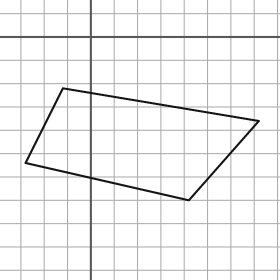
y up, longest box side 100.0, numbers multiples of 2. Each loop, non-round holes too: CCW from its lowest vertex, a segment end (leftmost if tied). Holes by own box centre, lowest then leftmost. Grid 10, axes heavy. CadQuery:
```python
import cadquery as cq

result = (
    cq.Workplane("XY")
    .moveTo(42.0, -70.0)
    .lineTo(72.0, -36.0)
    .lineTo(-12.0, -22.0)
    .lineTo(-28.0, -54.0)
    .close()
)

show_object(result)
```